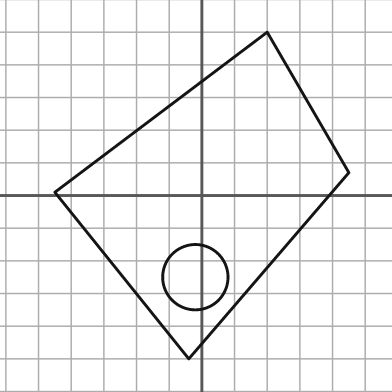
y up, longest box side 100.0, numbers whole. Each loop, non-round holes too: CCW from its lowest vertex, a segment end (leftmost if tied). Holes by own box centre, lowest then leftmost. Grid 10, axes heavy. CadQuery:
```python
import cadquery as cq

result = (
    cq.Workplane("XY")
    .moveTo(-4.0, -50.0)
    .lineTo(45.0, 7.0)
    .lineTo(20.0, 50.0)
    .lineTo(-45.0, 1.0)
    .close()
    .moveTo(-2.0, -25.0)
    .circle(10.0)
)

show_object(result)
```